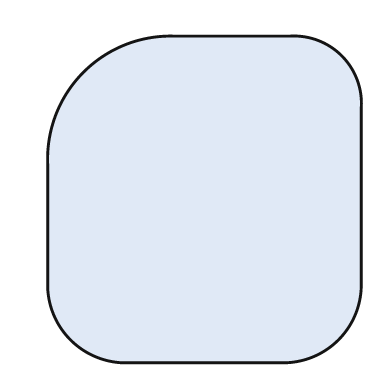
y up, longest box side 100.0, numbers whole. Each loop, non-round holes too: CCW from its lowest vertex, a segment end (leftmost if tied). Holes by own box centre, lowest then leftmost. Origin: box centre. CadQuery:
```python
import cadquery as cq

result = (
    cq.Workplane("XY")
    .moveTo(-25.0, -50.0)
    .lineTo(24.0, -50.0)
    .threePointArc((41.0, -43.0), (48.0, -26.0))
    .lineTo(48.0, 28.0)
    .threePointArc((42.0, 44.0), (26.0, 50.0))
    .lineTo(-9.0, 50.0)
    .threePointArc((-37.0, 39.0), (-48.0, 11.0))
    .lineTo(-48.0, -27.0)
    .threePointArc((-41.0, -43.0), (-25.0, -50.0))
    .close()
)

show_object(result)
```